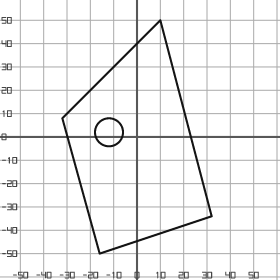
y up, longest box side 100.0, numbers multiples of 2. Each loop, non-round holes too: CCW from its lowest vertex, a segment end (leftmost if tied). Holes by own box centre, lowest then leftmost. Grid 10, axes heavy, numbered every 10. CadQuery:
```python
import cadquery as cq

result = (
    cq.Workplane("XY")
    .moveTo(-16.0, -50.0)
    .lineTo(32.0, -34.0)
    .lineTo(10.0, 50.0)
    .lineTo(-32.0, 8.0)
    .close()
    .moveTo(-12.0, 2.0)
    .circle(6.0)
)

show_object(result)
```